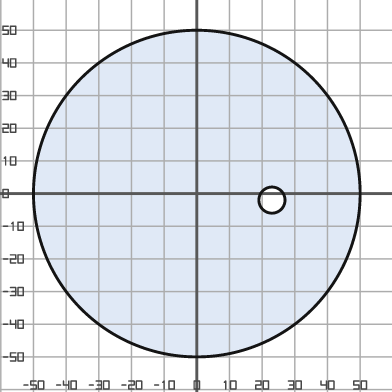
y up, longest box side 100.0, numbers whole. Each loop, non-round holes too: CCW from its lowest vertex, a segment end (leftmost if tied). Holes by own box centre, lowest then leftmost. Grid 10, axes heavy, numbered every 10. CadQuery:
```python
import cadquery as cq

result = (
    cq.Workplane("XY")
    .moveTo(0.0, 0.0)
    .circle(50.0)
    .moveTo(23.0, -2.0)
    .circle(4.0)
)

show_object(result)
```